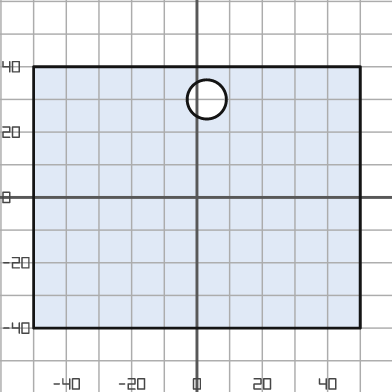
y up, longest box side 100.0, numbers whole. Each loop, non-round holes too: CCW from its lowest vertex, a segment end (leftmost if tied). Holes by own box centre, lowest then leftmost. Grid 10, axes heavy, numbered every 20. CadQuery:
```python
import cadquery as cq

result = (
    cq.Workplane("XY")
    .moveTo(-50.0, -40.0)
    .lineTo(50.0, -40.0)
    .lineTo(50.0, 40.0)
    .lineTo(-50.0, 40.0)
    .close()
    .moveTo(3.0, 30.0)
    .circle(6.0)
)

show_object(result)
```